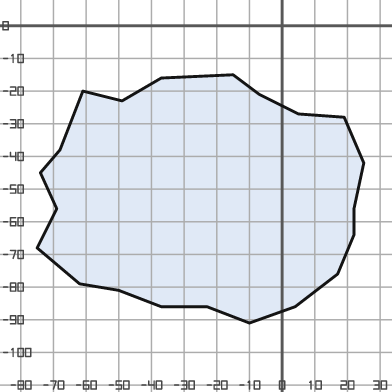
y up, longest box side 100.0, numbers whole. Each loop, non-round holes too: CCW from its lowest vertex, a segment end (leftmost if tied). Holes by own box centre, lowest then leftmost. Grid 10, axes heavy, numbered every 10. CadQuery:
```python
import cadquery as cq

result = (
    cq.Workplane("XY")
    .moveTo(-10.0, -91.0)
    .lineTo(4.0, -86.0)
    .lineTo(17.0, -76.0)
    .lineTo(22.0, -64.0)
    .lineTo(22.0, -56.0)
    .lineTo(25.0, -42.0)
    .lineTo(19.0, -28.0)
    .lineTo(5.0, -27.0)
    .lineTo(-7.0, -21.0)
    .lineTo(-15.0, -15.0)
    .lineTo(-37.0, -16.0)
    .lineTo(-49.0, -23.0)
    .lineTo(-61.0, -20.0)
    .lineTo(-68.0, -38.0)
    .lineTo(-74.0, -45.0)
    .lineTo(-69.0, -56.0)
    .lineTo(-75.0, -68.0)
    .lineTo(-62.0, -79.0)
    .lineTo(-50.0, -81.0)
    .lineTo(-37.0, -86.0)
    .lineTo(-23.0, -86.0)
    .close()
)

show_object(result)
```